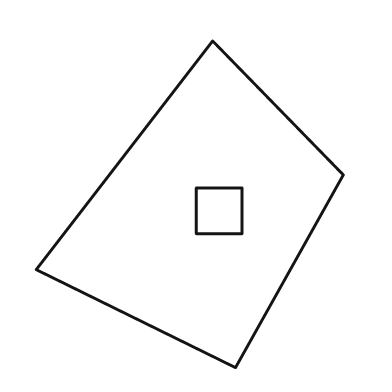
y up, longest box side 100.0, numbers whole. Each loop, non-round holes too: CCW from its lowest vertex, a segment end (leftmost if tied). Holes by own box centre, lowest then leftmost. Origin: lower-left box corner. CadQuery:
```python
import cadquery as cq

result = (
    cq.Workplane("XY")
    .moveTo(61.0, 0.0)
    .lineTo(94.0, 59.0)
    .lineTo(54.0, 100.0)
    .lineTo(0.0, 30.0)
    .close()
    .moveTo(49.0, 41.0)
    .lineTo(63.0, 41.0)
    .lineTo(63.0, 55.0)
    .lineTo(49.0, 55.0)
    .close()
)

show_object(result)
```